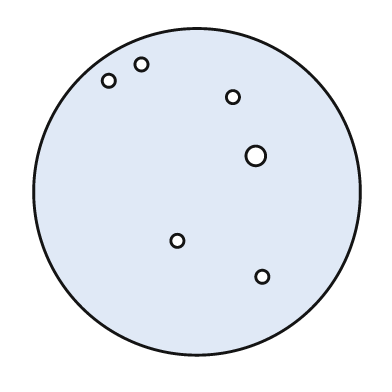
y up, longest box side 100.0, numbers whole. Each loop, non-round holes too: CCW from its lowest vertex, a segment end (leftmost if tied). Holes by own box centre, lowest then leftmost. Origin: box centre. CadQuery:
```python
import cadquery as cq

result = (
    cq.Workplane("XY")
    .moveTo(0.0, 0.0)
    .circle(50.0)
    .moveTo(20.0, -26.0)
    .circle(2.0)
    .moveTo(-6.0, -15.0)
    .circle(2.0)
    .moveTo(18.0, 11.0)
    .circle(3.0)
    .moveTo(11.0, 29.0)
    .circle(2.0)
    .moveTo(-27.0, 34.0)
    .circle(2.0)
    .moveTo(-17.0, 39.0)
    .circle(2.0)
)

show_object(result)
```